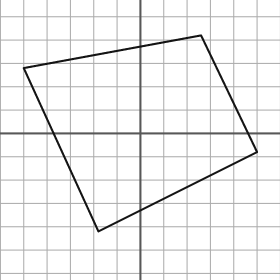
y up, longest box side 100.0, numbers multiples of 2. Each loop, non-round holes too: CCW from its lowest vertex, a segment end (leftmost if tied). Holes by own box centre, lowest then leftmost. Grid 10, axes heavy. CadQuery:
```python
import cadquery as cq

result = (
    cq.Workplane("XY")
    .moveTo(-18.0, -42.0)
    .lineTo(50.0, -8.0)
    .lineTo(26.0, 42.0)
    .lineTo(-50.0, 28.0)
    .close()
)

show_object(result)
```